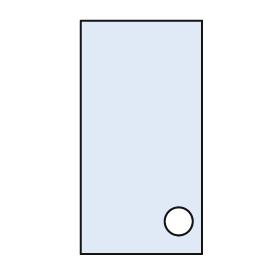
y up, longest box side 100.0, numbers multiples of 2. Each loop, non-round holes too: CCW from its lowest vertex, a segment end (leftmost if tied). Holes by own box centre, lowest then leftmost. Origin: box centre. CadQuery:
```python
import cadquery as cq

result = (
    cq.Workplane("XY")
    .moveTo(-26.0, -50.0)
    .lineTo(26.0, -50.0)
    .lineTo(26.0, 50.0)
    .lineTo(-26.0, 50.0)
    .close()
    .moveTo(16.0, -36.0)
    .circle(6.0)
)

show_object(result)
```